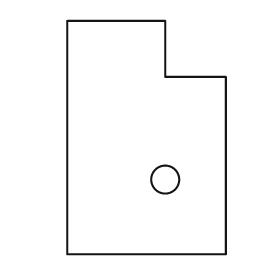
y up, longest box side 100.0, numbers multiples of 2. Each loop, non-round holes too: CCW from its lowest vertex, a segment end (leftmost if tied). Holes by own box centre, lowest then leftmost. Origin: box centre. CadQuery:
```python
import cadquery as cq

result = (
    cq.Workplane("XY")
    .moveTo(-34.0, -50.0)
    .lineTo(34.0, -50.0)
    .lineTo(34.0, 26.0)
    .lineTo(8.0, 26.0)
    .lineTo(8.0, 50.0)
    .lineTo(-34.0, 50.0)
    .close()
    .moveTo(8.0, -18.0)
    .circle(6.0)
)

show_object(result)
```